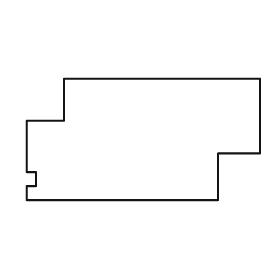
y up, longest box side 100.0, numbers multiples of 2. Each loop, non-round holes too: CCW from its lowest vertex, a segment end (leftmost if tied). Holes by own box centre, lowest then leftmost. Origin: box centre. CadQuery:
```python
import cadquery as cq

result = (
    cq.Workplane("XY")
    .moveTo(-50.0, -26.0)
    .lineTo(32.0, -26.0)
    .lineTo(32.0, -6.0)
    .lineTo(50.0, -6.0)
    .lineTo(50.0, 26.0)
    .lineTo(-34.0, 26.0)
    .lineTo(-34.0, 8.0)
    .lineTo(-50.0, 8.0)
    .lineTo(-50.0, -14.0)
    .lineTo(-46.0, -14.0)
    .lineTo(-46.0, -20.0)
    .lineTo(-50.0, -20.0)
    .close()
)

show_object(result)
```